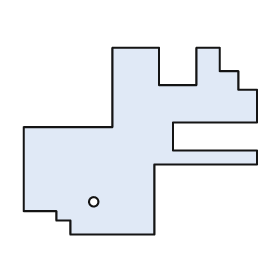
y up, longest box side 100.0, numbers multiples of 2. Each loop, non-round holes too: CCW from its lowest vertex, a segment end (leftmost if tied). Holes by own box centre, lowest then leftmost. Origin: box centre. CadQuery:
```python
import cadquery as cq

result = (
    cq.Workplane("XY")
    .moveTo(-30.0, -40.0)
    .lineTo(6.0, -40.0)
    .lineTo(6.0, -10.0)
    .lineTo(50.0, -10.0)
    .lineTo(50.0, -4.0)
    .lineTo(14.0, -4.0)
    .lineTo(14.0, 8.0)
    .lineTo(50.0, 8.0)
    .lineTo(50.0, 22.0)
    .lineTo(42.0, 22.0)
    .lineTo(42.0, 30.0)
    .lineTo(34.0, 30.0)
    .lineTo(34.0, 40.0)
    .lineTo(24.0, 40.0)
    .lineTo(24.0, 24.0)
    .lineTo(8.0, 24.0)
    .lineTo(8.0, 40.0)
    .lineTo(-12.0, 40.0)
    .lineTo(-12.0, 6.0)
    .lineTo(-50.0, 6.0)
    .lineTo(-50.0, -30.0)
    .lineTo(-36.0, -30.0)
    .lineTo(-36.0, -34.0)
    .lineTo(-30.0, -34.0)
    .close()
    .moveTo(-20.0, -26.0)
    .circle(2.0)
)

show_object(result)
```